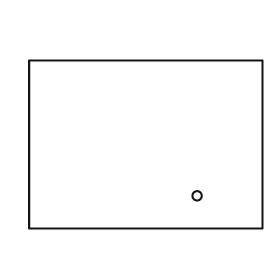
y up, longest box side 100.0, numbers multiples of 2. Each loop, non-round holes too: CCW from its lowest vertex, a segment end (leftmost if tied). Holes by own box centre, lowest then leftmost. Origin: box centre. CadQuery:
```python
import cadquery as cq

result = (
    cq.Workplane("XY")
    .moveTo(-50.0, -36.0)
    .lineTo(50.0, -36.0)
    .lineTo(50.0, 36.0)
    .lineTo(-50.0, 36.0)
    .close()
    .moveTo(22.0, -22.0)
    .circle(2.0)
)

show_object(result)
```